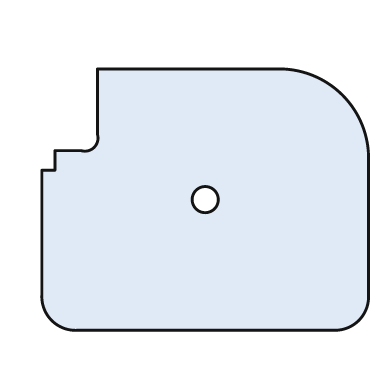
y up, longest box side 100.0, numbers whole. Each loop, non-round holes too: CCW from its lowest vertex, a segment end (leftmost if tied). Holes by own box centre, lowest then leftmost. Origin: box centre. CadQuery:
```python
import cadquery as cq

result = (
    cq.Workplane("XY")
    .moveTo(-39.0, -40.0)
    .lineTo(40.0, -40.0)
    .threePointArc((47.0, -37.0), (50.0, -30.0))
    .lineTo(50.0, 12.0)
    .threePointArc((42.0, 32.0), (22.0, 40.0))
    .lineTo(-33.0, 40.0)
    .lineTo(-33.0, 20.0)
    .threePointArc((-34.0, 16.0), (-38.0, 15.0))
    .lineTo(-46.0, 15.0)
    .lineTo(-46.0, 9.0)
    .lineTo(-50.0, 9.0)
    .lineTo(-50.0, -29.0)
    .threePointArc((-47.0, -37.0), (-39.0, -40.0))
    .close()
    .moveTo(0.0, 0.0)
    .circle(4.0)
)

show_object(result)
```